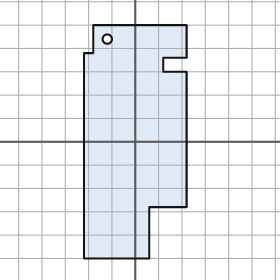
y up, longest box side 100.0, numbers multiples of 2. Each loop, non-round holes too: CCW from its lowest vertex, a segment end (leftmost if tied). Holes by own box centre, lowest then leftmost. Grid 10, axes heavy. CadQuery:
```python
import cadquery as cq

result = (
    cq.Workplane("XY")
    .moveTo(-22.0, -50.0)
    .lineTo(6.0, -50.0)
    .lineTo(6.0, -28.0)
    .lineTo(22.0, -28.0)
    .lineTo(22.0, 30.0)
    .lineTo(12.0, 30.0)
    .lineTo(12.0, 36.0)
    .lineTo(22.0, 36.0)
    .lineTo(22.0, 50.0)
    .lineTo(-18.0, 50.0)
    .lineTo(-18.0, 38.0)
    .lineTo(-22.0, 38.0)
    .close()
    .moveTo(-12.0, 44.0)
    .circle(2.0)
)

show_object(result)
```